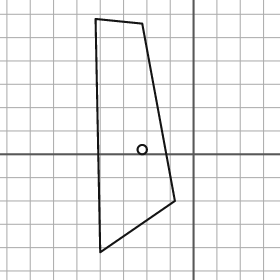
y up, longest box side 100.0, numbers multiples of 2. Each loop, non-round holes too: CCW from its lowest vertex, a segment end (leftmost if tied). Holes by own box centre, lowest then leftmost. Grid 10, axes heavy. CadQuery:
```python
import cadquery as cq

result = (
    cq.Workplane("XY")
    .moveTo(-40.0, -42.0)
    .lineTo(-8.0, -20.0)
    .lineTo(-22.0, 56.0)
    .lineTo(-42.0, 58.0)
    .close()
    .moveTo(-22.0, 2.0)
    .circle(2.0)
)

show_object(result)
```